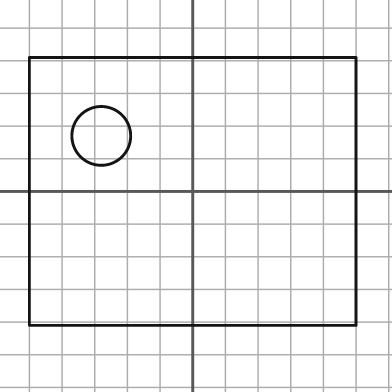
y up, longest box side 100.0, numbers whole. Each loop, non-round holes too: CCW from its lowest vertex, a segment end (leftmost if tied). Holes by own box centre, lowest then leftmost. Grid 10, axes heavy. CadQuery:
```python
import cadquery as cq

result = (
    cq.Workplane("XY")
    .moveTo(-50.0, -41.0)
    .lineTo(50.0, -41.0)
    .lineTo(50.0, 41.0)
    .lineTo(-50.0, 41.0)
    .close()
    .moveTo(-28.0, 17.0)
    .circle(9.0)
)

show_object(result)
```